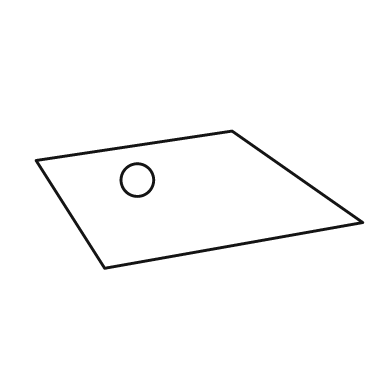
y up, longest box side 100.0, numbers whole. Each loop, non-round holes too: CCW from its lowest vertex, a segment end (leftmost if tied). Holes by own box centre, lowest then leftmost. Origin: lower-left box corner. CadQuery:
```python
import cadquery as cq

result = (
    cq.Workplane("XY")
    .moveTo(21.0, 0.0)
    .lineTo(100.0, 14.0)
    .lineTo(60.0, 42.0)
    .lineTo(0.0, 33.0)
    .close()
    .moveTo(31.0, 27.0)
    .circle(5.0)
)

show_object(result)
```